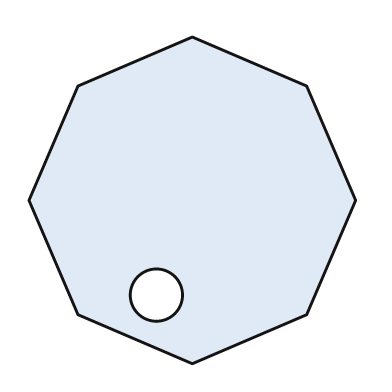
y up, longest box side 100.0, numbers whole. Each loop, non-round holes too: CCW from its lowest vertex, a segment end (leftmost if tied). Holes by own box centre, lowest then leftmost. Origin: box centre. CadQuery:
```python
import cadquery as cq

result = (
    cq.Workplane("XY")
    .moveTo(0.0, -50.0)
    .lineTo(35.0, -35.0)
    .lineTo(50.0, 0.0)
    .lineTo(35.0, 35.0)
    .lineTo(0.0, 50.0)
    .lineTo(-35.0, 35.0)
    .lineTo(-50.0, 0.0)
    .lineTo(-35.0, -35.0)
    .close()
    .moveTo(-11.0, -29.0)
    .circle(8.0)
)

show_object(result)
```